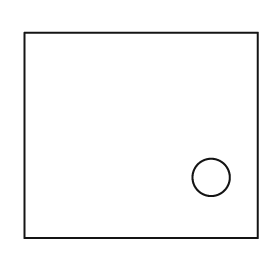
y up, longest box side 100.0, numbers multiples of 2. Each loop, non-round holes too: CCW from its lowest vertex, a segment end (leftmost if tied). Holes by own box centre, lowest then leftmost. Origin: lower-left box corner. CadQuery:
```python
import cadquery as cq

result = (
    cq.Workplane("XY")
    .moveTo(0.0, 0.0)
    .lineTo(100.0, 0.0)
    .lineTo(100.0, 88.0)
    .lineTo(0.0, 88.0)
    .close()
    .moveTo(80.0, 26.0)
    .circle(8.0)
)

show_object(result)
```